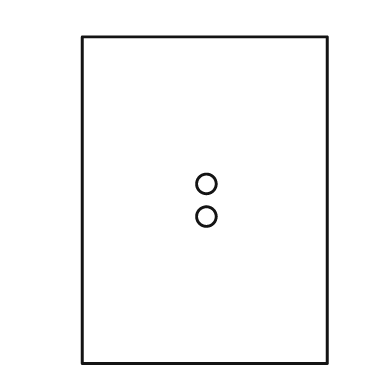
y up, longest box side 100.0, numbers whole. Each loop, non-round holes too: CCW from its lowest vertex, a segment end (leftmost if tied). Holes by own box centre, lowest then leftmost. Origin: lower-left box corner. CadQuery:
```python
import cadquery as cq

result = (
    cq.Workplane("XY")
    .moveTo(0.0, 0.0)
    .lineTo(75.0, 0.0)
    .lineTo(75.0, 100.0)
    .lineTo(0.0, 100.0)
    .close()
    .moveTo(38.0, 45.0)
    .circle(3.0)
    .moveTo(38.0, 55.0)
    .circle(3.0)
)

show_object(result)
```